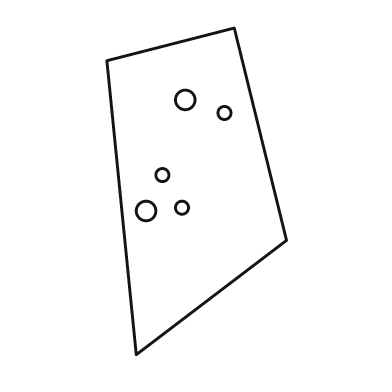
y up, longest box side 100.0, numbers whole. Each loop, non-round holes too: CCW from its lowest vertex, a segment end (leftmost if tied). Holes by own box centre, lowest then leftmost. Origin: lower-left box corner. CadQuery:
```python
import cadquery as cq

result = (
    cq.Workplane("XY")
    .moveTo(9.0, 0.0)
    .lineTo(55.0, 35.0)
    .lineTo(39.0, 100.0)
    .lineTo(0.0, 90.0)
    .close()
    .moveTo(12.0, 44.0)
    .circle(3.0)
    .moveTo(23.0, 45.0)
    .circle(2.0)
    .moveTo(17.0, 55.0)
    .circle(2.0)
    .moveTo(36.0, 74.0)
    .circle(2.0)
    .moveTo(24.0, 78.0)
    .circle(3.0)
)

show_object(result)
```